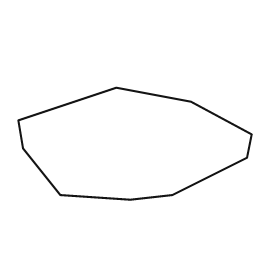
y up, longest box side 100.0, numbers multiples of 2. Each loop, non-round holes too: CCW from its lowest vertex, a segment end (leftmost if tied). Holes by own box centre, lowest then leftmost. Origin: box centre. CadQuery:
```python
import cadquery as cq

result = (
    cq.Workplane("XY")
    .moveTo(-2.0, -24.0)
    .lineTo(16.0, -22.0)
    .lineTo(48.0, -6.0)
    .lineTo(50.0, 4.0)
    .lineTo(24.0, 18.0)
    .lineTo(-8.0, 24.0)
    .lineTo(-50.0, 10.0)
    .lineTo(-48.0, -2.0)
    .lineTo(-32.0, -22.0)
    .close()
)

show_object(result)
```